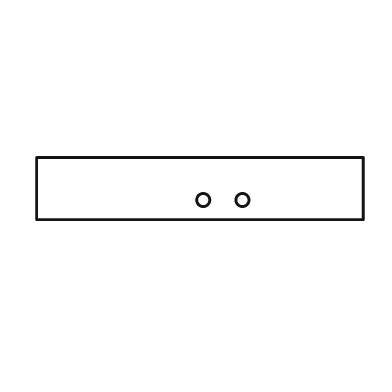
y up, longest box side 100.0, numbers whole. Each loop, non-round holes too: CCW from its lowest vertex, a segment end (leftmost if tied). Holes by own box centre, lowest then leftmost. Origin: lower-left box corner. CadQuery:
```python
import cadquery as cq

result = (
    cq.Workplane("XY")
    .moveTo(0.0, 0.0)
    .lineTo(100.0, 0.0)
    .lineTo(100.0, 19.0)
    .lineTo(0.0, 19.0)
    .close()
    .moveTo(51.0, 6.0)
    .circle(2.0)
    .moveTo(63.0, 6.0)
    .circle(2.0)
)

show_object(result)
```